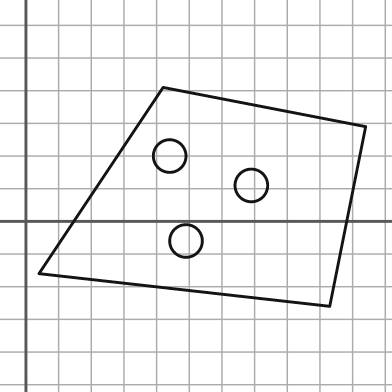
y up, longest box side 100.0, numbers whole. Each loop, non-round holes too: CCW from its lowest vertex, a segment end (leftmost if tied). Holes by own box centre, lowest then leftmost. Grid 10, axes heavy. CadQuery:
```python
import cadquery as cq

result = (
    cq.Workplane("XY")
    .moveTo(93.0, -26.0)
    .lineTo(104.0, 29.0)
    .lineTo(42.0, 41.0)
    .lineTo(4.0, -16.0)
    .close()
    .moveTo(49.0, -6.0)
    .circle(5.0)
    .moveTo(69.0, 11.0)
    .circle(5.0)
    .moveTo(44.0, 20.0)
    .circle(5.0)
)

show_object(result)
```